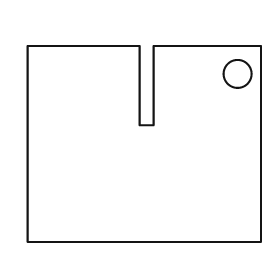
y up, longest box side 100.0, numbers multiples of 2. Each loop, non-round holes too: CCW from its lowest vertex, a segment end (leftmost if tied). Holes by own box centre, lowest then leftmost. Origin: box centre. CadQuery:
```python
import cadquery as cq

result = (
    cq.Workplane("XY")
    .moveTo(-50.0, -42.0)
    .lineTo(50.0, -42.0)
    .lineTo(50.0, 42.0)
    .lineTo(4.0, 42.0)
    .lineTo(4.0, 8.0)
    .lineTo(-2.0, 8.0)
    .lineTo(-2.0, 42.0)
    .lineTo(-50.0, 42.0)
    .close()
    .moveTo(40.0, 30.0)
    .circle(6.0)
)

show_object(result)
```